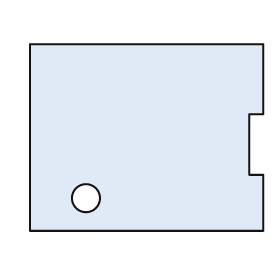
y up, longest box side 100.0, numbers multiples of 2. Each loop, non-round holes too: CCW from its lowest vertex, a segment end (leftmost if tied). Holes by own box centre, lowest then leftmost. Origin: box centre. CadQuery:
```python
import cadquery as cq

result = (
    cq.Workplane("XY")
    .moveTo(-50.0, -40.0)
    .lineTo(50.0, -40.0)
    .lineTo(50.0, -16.0)
    .lineTo(44.0, -16.0)
    .lineTo(44.0, 10.0)
    .lineTo(50.0, 10.0)
    .lineTo(50.0, 40.0)
    .lineTo(-50.0, 40.0)
    .close()
    .moveTo(-26.0, -26.0)
    .circle(6.0)
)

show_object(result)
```